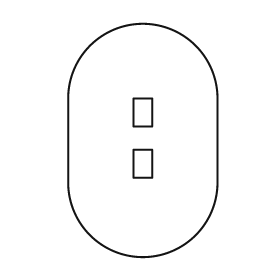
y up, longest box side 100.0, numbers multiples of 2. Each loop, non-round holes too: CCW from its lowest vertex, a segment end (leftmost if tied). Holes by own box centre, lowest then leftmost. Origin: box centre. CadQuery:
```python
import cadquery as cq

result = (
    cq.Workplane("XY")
    .moveTo(-32.0, -18.0)
    .threePointArc((0.0, -50.0), (32.0, -18.0))
    .lineTo(32.0, 18.0)
    .threePointArc((0.0, 50.0), (-32.0, 18.0))
    .close()
    .moveTo(-4.0, -16.0)
    .lineTo(4.0, -16.0)
    .lineTo(4.0, -4.0)
    .lineTo(-4.0, -4.0)
    .close()
    .moveTo(-4.0, 6.0)
    .lineTo(4.0, 6.0)
    .lineTo(4.0, 18.0)
    .lineTo(-4.0, 18.0)
    .close()
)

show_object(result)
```